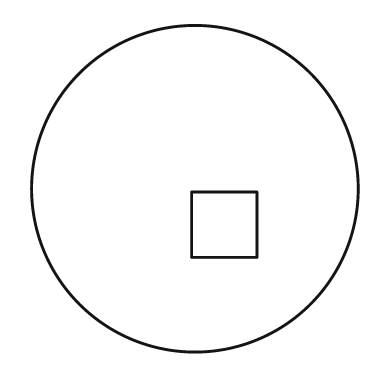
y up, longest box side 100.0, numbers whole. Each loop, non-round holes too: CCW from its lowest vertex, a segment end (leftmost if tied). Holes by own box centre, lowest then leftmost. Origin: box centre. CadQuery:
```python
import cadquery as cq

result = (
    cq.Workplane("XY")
    .moveTo(0.0, 0.0)
    .circle(50.0)
    .moveTo(-1.0, -21.0)
    .lineTo(19.0, -21.0)
    .lineTo(19.0, -1.0)
    .lineTo(-1.0, -1.0)
    .close()
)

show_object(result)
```